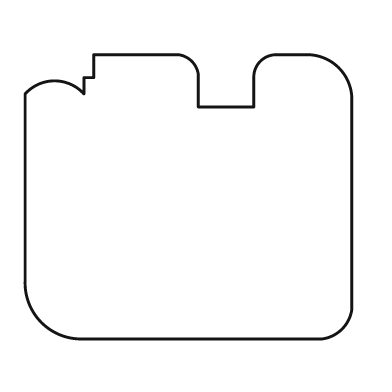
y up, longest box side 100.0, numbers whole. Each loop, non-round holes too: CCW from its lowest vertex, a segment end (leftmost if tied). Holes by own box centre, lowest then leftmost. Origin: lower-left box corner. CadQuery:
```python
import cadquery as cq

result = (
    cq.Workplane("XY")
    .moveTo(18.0, 0.0)
    .lineTo(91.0, 0.0)
    .threePointArc((97.0, 3.0), (100.0, 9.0))
    .lineTo(100.0, 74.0)
    .threePointArc((96.0, 83.0), (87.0, 87.0))
    .lineTo(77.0, 87.0)
    .threePointArc((72.0, 85.0), (70.0, 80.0))
    .lineTo(70.0, 71.0)
    .lineTo(53.0, 71.0)
    .lineTo(53.0, 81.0)
    .threePointArc((51.0, 85.0), (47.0, 87.0))
    .lineTo(21.0, 87.0)
    .lineTo(21.0, 80.0)
    .lineTo(18.0, 80.0)
    .lineTo(18.0, 75.0)
    .threePointArc((9.0, 79.0), (0.0, 75.0))
    .lineTo(0.0, 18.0)
    .threePointArc((5.0, 5.0), (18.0, 0.0))
    .close()
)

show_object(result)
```